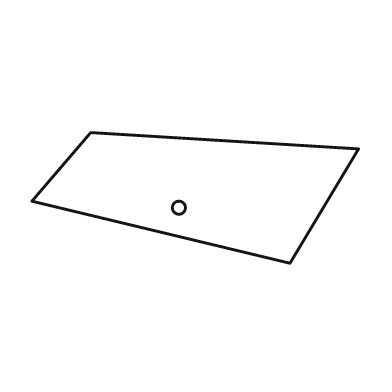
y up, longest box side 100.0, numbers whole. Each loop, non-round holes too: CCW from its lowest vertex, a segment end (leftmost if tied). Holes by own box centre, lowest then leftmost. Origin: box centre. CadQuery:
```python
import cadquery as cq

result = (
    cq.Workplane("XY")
    .moveTo(29.0, -20.0)
    .lineTo(50.0, 15.0)
    .lineTo(-32.0, 20.0)
    .lineTo(-50.0, -1.0)
    .close()
    .moveTo(-5.0, -3.0)
    .circle(2.0)
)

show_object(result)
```